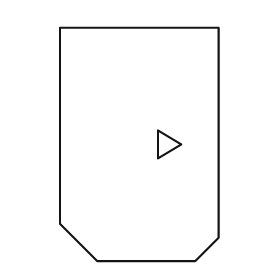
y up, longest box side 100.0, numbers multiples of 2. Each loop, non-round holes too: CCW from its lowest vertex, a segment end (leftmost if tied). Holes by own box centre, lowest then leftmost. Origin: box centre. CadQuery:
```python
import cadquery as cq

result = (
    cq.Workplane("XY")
    .moveTo(-18.0, -50.0)
    .lineTo(24.0, -50.0)
    .lineTo(34.0, -40.0)
    .lineTo(34.0, 50.0)
    .lineTo(-34.0, 50.0)
    .lineTo(-34.0, -34.0)
    .close()
    .moveTo(8.0, -6.0)
    .lineTo(18.0, 0.0)
    .lineTo(8.0, 6.0)
    .close()
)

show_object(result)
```